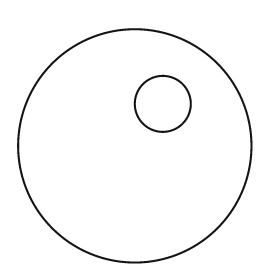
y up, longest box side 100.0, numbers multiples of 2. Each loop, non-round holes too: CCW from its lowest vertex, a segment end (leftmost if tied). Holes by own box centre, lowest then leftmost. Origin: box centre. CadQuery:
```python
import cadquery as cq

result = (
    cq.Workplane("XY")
    .moveTo(0.0, 0.0)
    .circle(50.0)
    .moveTo(12.0, 18.0)
    .circle(12.0)
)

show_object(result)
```